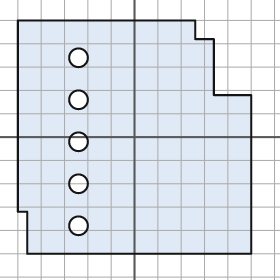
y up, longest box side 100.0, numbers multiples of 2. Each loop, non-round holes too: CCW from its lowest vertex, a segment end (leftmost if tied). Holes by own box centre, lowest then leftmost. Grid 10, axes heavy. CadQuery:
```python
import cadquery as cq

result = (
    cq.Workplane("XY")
    .moveTo(-46.0, -50.0)
    .lineTo(50.0, -50.0)
    .lineTo(50.0, 18.0)
    .lineTo(34.0, 18.0)
    .lineTo(34.0, 42.0)
    .lineTo(26.0, 42.0)
    .lineTo(26.0, 50.0)
    .lineTo(-50.0, 50.0)
    .lineTo(-50.0, -32.0)
    .lineTo(-46.0, -32.0)
    .close()
    .moveTo(-24.0, -38.0)
    .circle(4.0)
    .moveTo(-24.0, -20.0)
    .circle(4.0)
    .moveTo(-24.0, -2.0)
    .circle(4.0)
    .moveTo(-24.0, 16.0)
    .circle(4.0)
    .moveTo(-24.0, 34.0)
    .circle(4.0)
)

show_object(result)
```